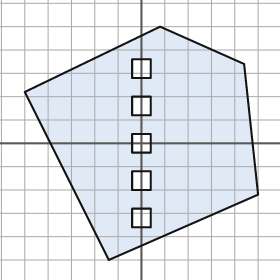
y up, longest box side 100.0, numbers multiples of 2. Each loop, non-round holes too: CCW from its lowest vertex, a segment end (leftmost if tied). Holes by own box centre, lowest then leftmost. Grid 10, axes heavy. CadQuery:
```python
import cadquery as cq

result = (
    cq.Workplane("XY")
    .moveTo(-14.0, -50.0)
    .lineTo(50.0, -22.0)
    .lineTo(44.0, 34.0)
    .lineTo(8.0, 50.0)
    .lineTo(-50.0, 22.0)
    .close()
    .moveTo(-4.0, -36.0)
    .lineTo(4.0, -36.0)
    .lineTo(4.0, -28.0)
    .lineTo(-4.0, -28.0)
    .close()
    .moveTo(-4.0, -20.0)
    .lineTo(4.0, -20.0)
    .lineTo(4.0, -12.0)
    .lineTo(-4.0, -12.0)
    .close()
    .moveTo(-4.0, -4.0)
    .lineTo(4.0, -4.0)
    .lineTo(4.0, 4.0)
    .lineTo(-4.0, 4.0)
    .close()
    .moveTo(-4.0, 12.0)
    .lineTo(4.0, 12.0)
    .lineTo(4.0, 20.0)
    .lineTo(-4.0, 20.0)
    .close()
    .moveTo(-4.0, 28.0)
    .lineTo(4.0, 28.0)
    .lineTo(4.0, 36.0)
    .lineTo(-4.0, 36.0)
    .close()
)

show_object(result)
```